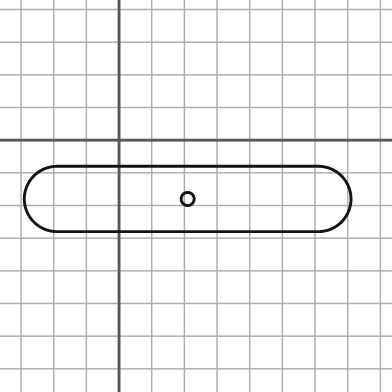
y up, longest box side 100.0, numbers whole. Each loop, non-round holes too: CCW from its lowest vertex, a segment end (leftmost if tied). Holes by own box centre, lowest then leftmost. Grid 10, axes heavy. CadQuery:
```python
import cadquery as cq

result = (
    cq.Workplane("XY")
    .moveTo(-19.0, -28.0)
    .lineTo(61.0, -28.0)
    .threePointArc((71.0, -18.0), (61.0, -8.0))
    .lineTo(-19.0, -8.0)
    .threePointArc((-29.0, -18.0), (-19.0, -28.0))
    .close()
    .moveTo(21.0, -18.0)
    .circle(2.0)
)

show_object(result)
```